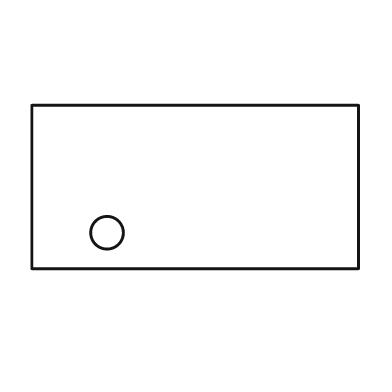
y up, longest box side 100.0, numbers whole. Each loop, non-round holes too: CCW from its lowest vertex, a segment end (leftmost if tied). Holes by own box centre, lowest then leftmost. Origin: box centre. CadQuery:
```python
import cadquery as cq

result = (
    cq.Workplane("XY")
    .moveTo(-50.0, -25.0)
    .lineTo(50.0, -25.0)
    .lineTo(50.0, 25.0)
    .lineTo(-50.0, 25.0)
    .close()
    .moveTo(-27.0, -14.0)
    .circle(5.0)
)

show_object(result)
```